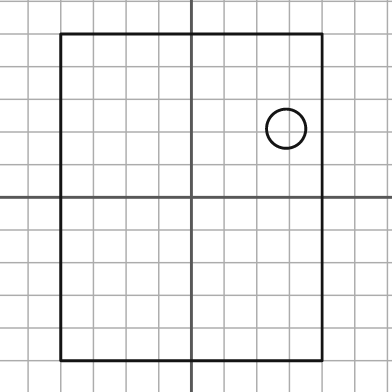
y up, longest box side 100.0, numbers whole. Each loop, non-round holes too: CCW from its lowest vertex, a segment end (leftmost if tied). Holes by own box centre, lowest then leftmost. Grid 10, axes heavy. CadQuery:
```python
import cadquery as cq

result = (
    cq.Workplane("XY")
    .moveTo(-40.0, -50.0)
    .lineTo(40.0, -50.0)
    .lineTo(40.0, 50.0)
    .lineTo(-40.0, 50.0)
    .close()
    .moveTo(29.0, 21.0)
    .circle(6.0)
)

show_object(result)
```